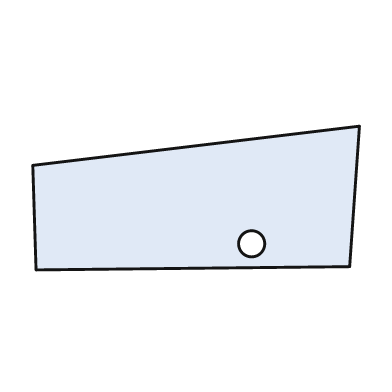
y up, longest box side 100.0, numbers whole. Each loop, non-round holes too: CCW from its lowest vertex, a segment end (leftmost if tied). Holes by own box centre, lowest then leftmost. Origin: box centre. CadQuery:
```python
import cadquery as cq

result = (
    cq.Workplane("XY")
    .moveTo(-49.0, -22.0)
    .lineTo(47.0, -21.0)
    .lineTo(50.0, 22.0)
    .lineTo(-50.0, 10.0)
    .close()
    .moveTo(17.0, -14.0)
    .circle(4.0)
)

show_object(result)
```